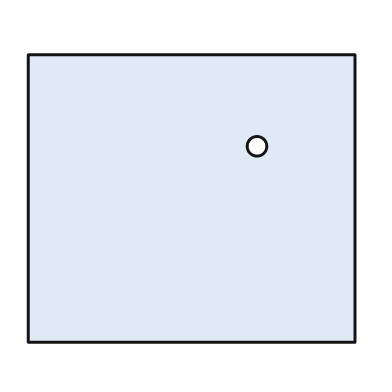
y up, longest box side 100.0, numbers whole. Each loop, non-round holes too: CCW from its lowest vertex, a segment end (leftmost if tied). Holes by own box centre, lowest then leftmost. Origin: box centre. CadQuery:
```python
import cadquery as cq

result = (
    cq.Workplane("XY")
    .moveTo(-50.0, -44.0)
    .lineTo(50.0, -44.0)
    .lineTo(50.0, 44.0)
    .lineTo(-50.0, 44.0)
    .close()
    .moveTo(20.0, 16.0)
    .circle(3.0)
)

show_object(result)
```